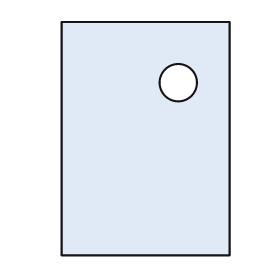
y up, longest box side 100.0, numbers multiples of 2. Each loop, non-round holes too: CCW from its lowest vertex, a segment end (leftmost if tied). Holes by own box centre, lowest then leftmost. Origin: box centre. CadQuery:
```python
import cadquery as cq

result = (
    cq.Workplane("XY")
    .moveTo(-36.0, -50.0)
    .lineTo(36.0, -50.0)
    .lineTo(36.0, 50.0)
    .lineTo(-36.0, 50.0)
    .close()
    .moveTo(14.0, 24.0)
    .circle(8.0)
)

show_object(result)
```